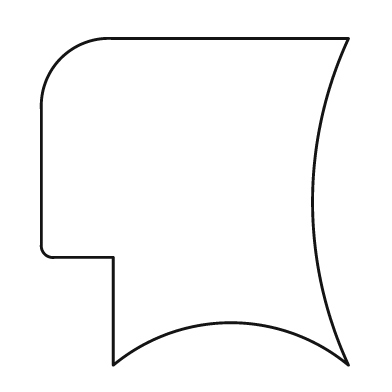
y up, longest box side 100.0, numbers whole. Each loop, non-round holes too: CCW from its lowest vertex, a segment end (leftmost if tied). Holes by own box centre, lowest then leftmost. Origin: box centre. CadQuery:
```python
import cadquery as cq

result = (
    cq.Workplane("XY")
    .moveTo(-25.0, -50.0)
    .threePointArc((11.0, -37.0), (47.0, -50.0))
    .threePointArc((36.0, 0.0), (47.0, 50.0))
    .lineTo(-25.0, 50.0)
    .threePointArc((-41.0, 44.0), (-47.0, 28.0))
    .lineTo(-47.0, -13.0)
    .threePointArc((-46.0, -16.0), (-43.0, -17.0))
    .lineTo(-25.0, -17.0)
    .close()
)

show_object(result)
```